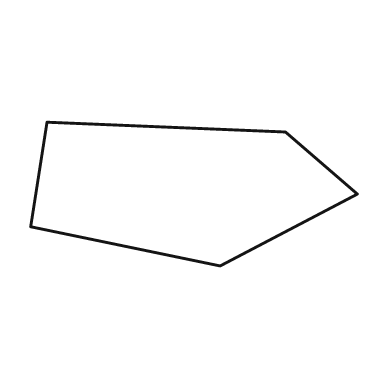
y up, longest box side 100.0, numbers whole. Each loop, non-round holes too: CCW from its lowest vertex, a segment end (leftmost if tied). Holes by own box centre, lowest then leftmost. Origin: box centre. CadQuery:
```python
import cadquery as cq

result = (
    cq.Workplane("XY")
    .moveTo(8.0, -22.0)
    .lineTo(50.0, 0.0)
    .lineTo(28.0, 19.0)
    .lineTo(-45.0, 22.0)
    .lineTo(-50.0, -10.0)
    .close()
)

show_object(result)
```